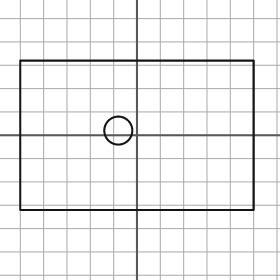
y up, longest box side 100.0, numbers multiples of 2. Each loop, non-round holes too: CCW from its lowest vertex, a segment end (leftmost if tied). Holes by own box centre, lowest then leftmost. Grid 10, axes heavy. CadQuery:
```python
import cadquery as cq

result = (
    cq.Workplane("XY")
    .moveTo(-50.0, -32.0)
    .lineTo(50.0, -32.0)
    .lineTo(50.0, 32.0)
    .lineTo(-50.0, 32.0)
    .close()
    .moveTo(-8.0, 2.0)
    .circle(6.0)
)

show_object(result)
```